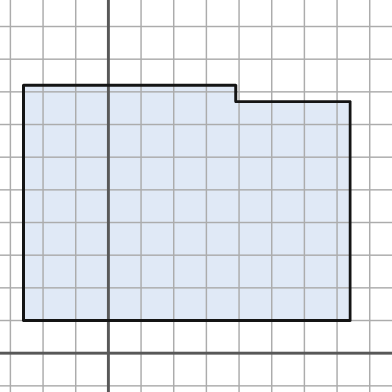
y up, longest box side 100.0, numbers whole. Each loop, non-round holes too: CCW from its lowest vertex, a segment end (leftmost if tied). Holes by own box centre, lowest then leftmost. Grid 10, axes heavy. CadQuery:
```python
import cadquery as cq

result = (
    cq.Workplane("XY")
    .moveTo(-26.0, 10.0)
    .lineTo(74.0, 10.0)
    .lineTo(74.0, 77.0)
    .lineTo(39.0, 77.0)
    .lineTo(39.0, 82.0)
    .lineTo(-26.0, 82.0)
    .close()
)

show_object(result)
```